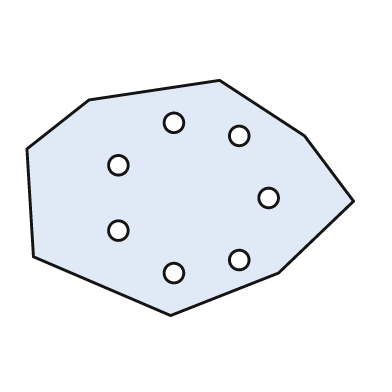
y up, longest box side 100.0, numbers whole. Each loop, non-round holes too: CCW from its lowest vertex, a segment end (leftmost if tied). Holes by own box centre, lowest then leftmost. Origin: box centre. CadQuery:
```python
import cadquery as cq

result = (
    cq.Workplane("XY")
    .moveTo(-6.0, -36.0)
    .lineTo(27.0, -23.0)
    .lineTo(50.0, -1.0)
    .lineTo(35.0, 19.0)
    .lineTo(9.0, 36.0)
    .lineTo(-31.0, 30.0)
    .lineTo(-50.0, 15.0)
    .lineTo(-48.0, -18.0)
    .close()
    .moveTo(-5.0, -23.0)
    .circle(3.0)
    .moveTo(15.0, -19.0)
    .circle(3.0)
    .moveTo(-22.0, -10.0)
    .circle(3.0)
    .moveTo(24.0, 0.0)
    .circle(3.0)
    .moveTo(-22.0, 10.0)
    .circle(3.0)
    .moveTo(15.0, 19.0)
    .circle(3.0)
    .moveTo(-5.0, 23.0)
    .circle(3.0)
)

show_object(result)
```